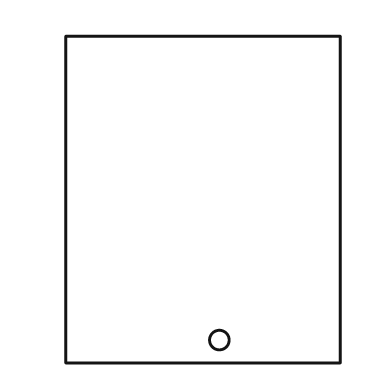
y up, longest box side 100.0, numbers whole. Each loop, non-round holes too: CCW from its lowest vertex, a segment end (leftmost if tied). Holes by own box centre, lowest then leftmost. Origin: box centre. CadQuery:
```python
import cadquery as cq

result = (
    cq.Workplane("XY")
    .moveTo(-42.0, -50.0)
    .lineTo(42.0, -50.0)
    .lineTo(42.0, 50.0)
    .lineTo(-42.0, 50.0)
    .close()
    .moveTo(5.0, -43.0)
    .circle(3.0)
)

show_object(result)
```